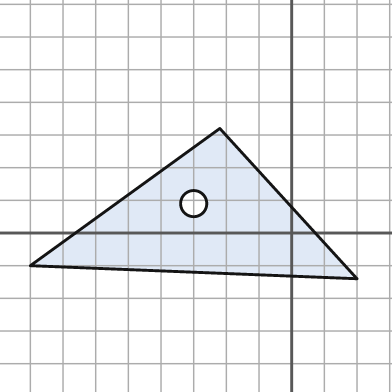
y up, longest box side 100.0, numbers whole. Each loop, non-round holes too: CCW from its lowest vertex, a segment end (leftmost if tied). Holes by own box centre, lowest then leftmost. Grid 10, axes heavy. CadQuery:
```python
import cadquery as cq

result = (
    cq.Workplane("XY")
    .moveTo(20.0, -14.0)
    .lineTo(-22.0, 32.0)
    .lineTo(-80.0, -10.0)
    .close()
    .moveTo(-30.0, 9.0)
    .circle(4.0)
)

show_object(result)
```